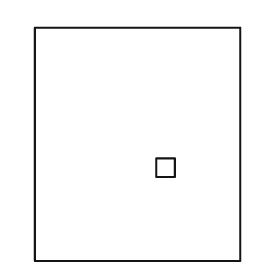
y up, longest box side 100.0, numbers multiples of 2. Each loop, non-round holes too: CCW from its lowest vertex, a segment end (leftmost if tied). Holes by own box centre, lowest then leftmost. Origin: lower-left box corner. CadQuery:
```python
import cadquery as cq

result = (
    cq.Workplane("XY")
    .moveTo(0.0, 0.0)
    .lineTo(88.0, 0.0)
    .lineTo(88.0, 100.0)
    .lineTo(0.0, 100.0)
    .close()
    .moveTo(52.0, 36.0)
    .lineTo(60.0, 36.0)
    .lineTo(60.0, 44.0)
    .lineTo(52.0, 44.0)
    .close()
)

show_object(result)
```